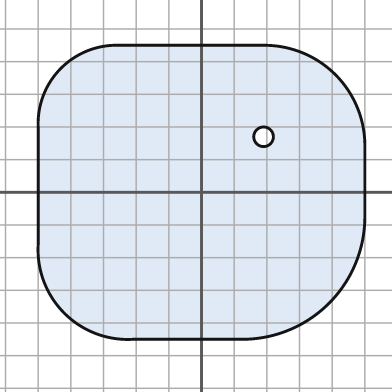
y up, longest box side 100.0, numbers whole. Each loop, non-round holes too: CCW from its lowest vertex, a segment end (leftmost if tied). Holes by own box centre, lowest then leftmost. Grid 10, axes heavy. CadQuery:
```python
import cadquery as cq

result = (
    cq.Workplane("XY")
    .moveTo(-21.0, -45.0)
    .lineTo(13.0, -45.0)
    .threePointArc((39.0, -34.0), (50.0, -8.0))
    .lineTo(50.0, 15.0)
    .threePointArc((41.0, 36.0), (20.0, 45.0))
    .lineTo(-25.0, 45.0)
    .threePointArc((-43.0, 38.0), (-50.0, 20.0))
    .lineTo(-50.0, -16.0)
    .threePointArc((-42.0, -37.0), (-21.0, -45.0))
    .close()
    .moveTo(19.0, 17.0)
    .circle(3.0)
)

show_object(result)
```